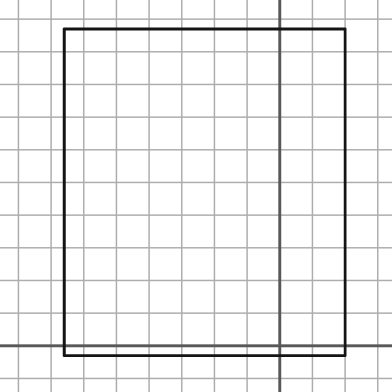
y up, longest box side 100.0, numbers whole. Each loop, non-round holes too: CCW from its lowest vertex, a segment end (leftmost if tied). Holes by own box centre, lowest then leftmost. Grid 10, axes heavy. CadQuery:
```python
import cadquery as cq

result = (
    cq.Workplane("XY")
    .moveTo(-66.0, -3.0)
    .lineTo(20.0, -3.0)
    .lineTo(20.0, 97.0)
    .lineTo(-66.0, 97.0)
    .close()
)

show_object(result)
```